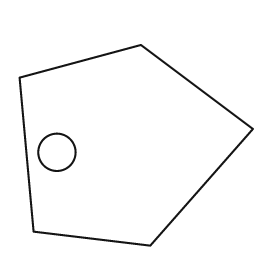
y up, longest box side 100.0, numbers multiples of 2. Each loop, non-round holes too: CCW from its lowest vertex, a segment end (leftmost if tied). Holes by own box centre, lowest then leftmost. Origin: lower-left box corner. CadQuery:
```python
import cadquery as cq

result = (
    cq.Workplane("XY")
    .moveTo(56.0, 0.0)
    .lineTo(100.0, 50.0)
    .lineTo(52.0, 86.0)
    .lineTo(0.0, 72.0)
    .lineTo(6.0, 6.0)
    .close()
    .moveTo(16.0, 40.0)
    .circle(8.0)
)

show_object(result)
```